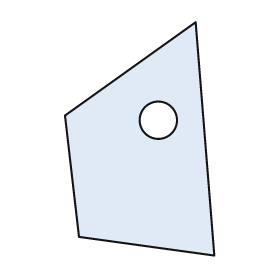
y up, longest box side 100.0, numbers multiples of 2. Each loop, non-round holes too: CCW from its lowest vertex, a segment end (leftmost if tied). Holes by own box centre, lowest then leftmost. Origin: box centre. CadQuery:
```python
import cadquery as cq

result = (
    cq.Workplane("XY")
    .moveTo(32.0, -50.0)
    .lineTo(24.0, 50.0)
    .lineTo(-32.0, 10.0)
    .lineTo(-26.0, -42.0)
    .close()
    .moveTo(8.0, 8.0)
    .circle(8.0)
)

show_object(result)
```